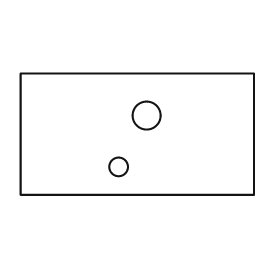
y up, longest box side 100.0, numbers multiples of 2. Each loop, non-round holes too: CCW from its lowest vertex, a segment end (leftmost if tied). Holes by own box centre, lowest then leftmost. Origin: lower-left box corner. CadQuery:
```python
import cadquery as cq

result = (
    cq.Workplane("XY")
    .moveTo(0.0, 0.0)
    .lineTo(100.0, 0.0)
    .lineTo(100.0, 52.0)
    .lineTo(0.0, 52.0)
    .close()
    .moveTo(42.0, 12.0)
    .circle(4.0)
    .moveTo(54.0, 34.0)
    .circle(6.0)
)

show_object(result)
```